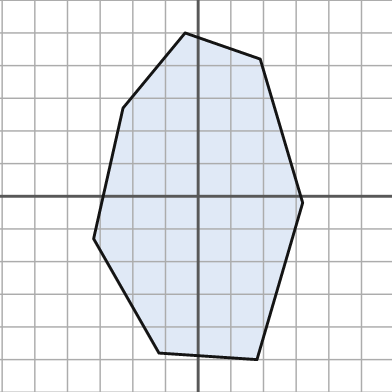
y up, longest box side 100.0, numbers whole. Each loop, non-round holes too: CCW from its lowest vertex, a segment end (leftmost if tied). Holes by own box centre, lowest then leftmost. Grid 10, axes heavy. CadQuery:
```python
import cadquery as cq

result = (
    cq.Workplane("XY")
    .moveTo(18.0, -50.0)
    .lineTo(32.0, -2.0)
    .lineTo(19.0, 42.0)
    .lineTo(-4.0, 50.0)
    .lineTo(-23.0, 27.0)
    .lineTo(-32.0, -13.0)
    .lineTo(-12.0, -48.0)
    .close()
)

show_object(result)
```